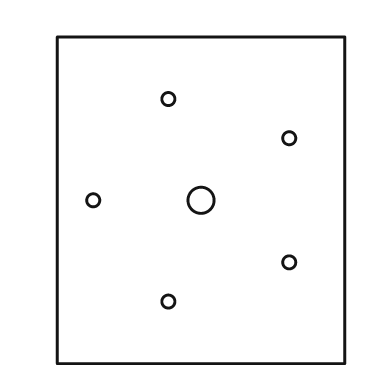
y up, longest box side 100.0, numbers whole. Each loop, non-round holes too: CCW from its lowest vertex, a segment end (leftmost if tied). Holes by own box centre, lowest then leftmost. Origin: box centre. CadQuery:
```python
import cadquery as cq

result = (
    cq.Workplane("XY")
    .moveTo(-44.0, -50.0)
    .lineTo(44.0, -50.0)
    .lineTo(44.0, 50.0)
    .lineTo(-44.0, 50.0)
    .close()
    .moveTo(-10.0, -31.0)
    .circle(2.0)
    .moveTo(27.0, -19.0)
    .circle(2.0)
    .moveTo(-33.0, 0.0)
    .circle(2.0)
    .moveTo(0.0, 0.0)
    .circle(4.0)
    .moveTo(27.0, 19.0)
    .circle(2.0)
    .moveTo(-10.0, 31.0)
    .circle(2.0)
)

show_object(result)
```